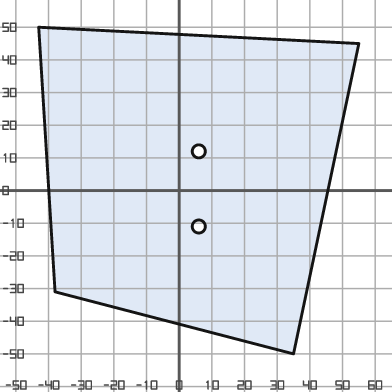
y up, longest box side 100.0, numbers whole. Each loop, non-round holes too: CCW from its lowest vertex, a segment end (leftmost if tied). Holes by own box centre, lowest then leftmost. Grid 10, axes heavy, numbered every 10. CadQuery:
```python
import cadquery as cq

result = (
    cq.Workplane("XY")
    .moveTo(35.0, -50.0)
    .lineTo(55.0, 45.0)
    .lineTo(-43.0, 50.0)
    .lineTo(-38.0, -31.0)
    .close()
    .moveTo(6.0, -11.0)
    .circle(2.0)
    .moveTo(6.0, 12.0)
    .circle(2.0)
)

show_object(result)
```